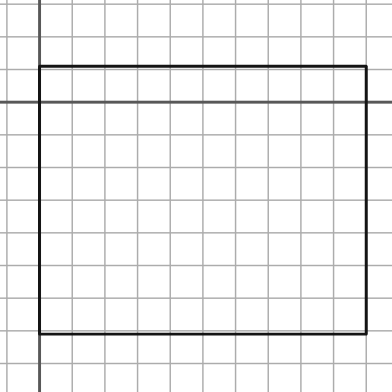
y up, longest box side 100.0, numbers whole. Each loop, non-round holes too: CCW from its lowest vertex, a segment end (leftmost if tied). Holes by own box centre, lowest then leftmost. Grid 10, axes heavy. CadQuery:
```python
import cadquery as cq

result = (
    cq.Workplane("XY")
    .moveTo(0.0, -71.0)
    .lineTo(100.0, -71.0)
    .lineTo(100.0, 11.0)
    .lineTo(0.0, 11.0)
    .close()
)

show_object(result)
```